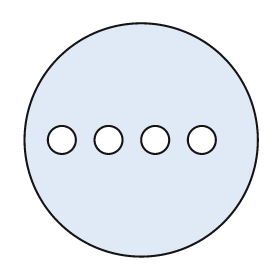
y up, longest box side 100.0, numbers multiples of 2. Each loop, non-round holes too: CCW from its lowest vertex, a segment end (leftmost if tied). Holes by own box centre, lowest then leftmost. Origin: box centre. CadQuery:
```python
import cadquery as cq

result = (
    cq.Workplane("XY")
    .moveTo(0.0, 0.0)
    .circle(50.0)
    .moveTo(-34.0, 0.0)
    .circle(6.0)
    .moveTo(-14.0, 0.0)
    .circle(6.0)
    .moveTo(6.0, 0.0)
    .circle(6.0)
    .moveTo(26.0, 0.0)
    .circle(6.0)
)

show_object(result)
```